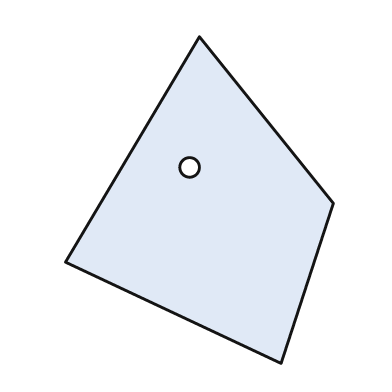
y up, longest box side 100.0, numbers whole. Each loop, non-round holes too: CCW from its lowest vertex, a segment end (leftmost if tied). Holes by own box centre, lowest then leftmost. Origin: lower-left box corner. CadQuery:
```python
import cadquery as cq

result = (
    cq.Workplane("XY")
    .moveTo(66.0, 0.0)
    .lineTo(82.0, 49.0)
    .lineTo(41.0, 100.0)
    .lineTo(0.0, 31.0)
    .close()
    .moveTo(38.0, 60.0)
    .circle(3.0)
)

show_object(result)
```